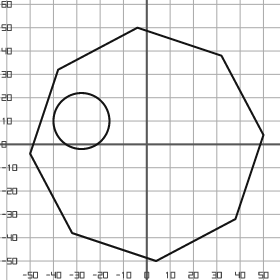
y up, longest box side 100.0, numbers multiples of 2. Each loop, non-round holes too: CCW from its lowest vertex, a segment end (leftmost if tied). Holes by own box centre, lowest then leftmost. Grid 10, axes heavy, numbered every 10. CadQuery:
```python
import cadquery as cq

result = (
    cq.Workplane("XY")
    .moveTo(4.0, -50.0)
    .lineTo(38.0, -32.0)
    .lineTo(50.0, 4.0)
    .lineTo(32.0, 38.0)
    .lineTo(-4.0, 50.0)
    .lineTo(-38.0, 32.0)
    .lineTo(-50.0, -4.0)
    .lineTo(-32.0, -38.0)
    .close()
    .moveTo(-28.0, 10.0)
    .circle(12.0)
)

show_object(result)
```